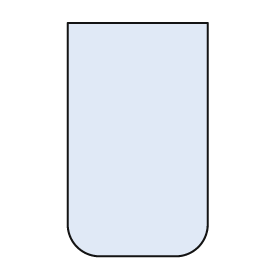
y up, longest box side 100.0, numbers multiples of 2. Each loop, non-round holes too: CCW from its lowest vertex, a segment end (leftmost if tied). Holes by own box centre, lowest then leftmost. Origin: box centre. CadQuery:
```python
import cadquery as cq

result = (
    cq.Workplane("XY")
    .moveTo(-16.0, -50.0)
    .lineTo(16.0, -50.0)
    .threePointArc((26.0, -46.0), (30.0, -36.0))
    .lineTo(30.0, 50.0)
    .lineTo(-30.0, 50.0)
    .lineTo(-30.0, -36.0)
    .threePointArc((-26.0, -46.0), (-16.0, -50.0))
    .close()
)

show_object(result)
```